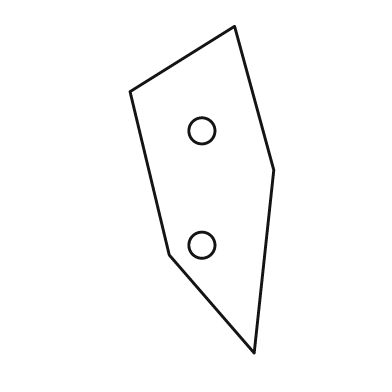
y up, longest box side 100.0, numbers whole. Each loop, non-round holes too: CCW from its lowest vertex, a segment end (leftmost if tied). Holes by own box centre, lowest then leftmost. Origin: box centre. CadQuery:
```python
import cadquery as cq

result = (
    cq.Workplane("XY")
    .moveTo(16.0, -50.0)
    .lineTo(22.0, 6.0)
    .lineTo(10.0, 50.0)
    .lineTo(-22.0, 30.0)
    .lineTo(-10.0, -20.0)
    .close()
    .moveTo(0.0, -17.0)
    .circle(4.0)
    .moveTo(0.0, 18.0)
    .circle(4.0)
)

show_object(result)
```